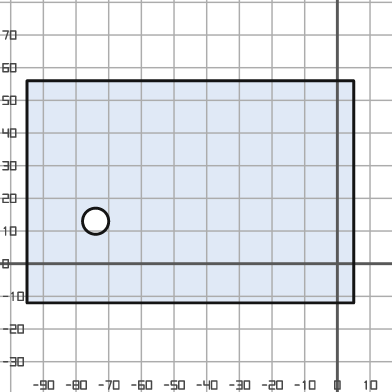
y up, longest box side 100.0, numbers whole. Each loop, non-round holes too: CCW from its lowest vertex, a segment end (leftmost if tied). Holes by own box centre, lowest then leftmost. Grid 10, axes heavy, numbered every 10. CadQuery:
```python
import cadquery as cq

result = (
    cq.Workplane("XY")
    .moveTo(-95.0, -12.0)
    .lineTo(5.0, -12.0)
    .lineTo(5.0, 56.0)
    .lineTo(-95.0, 56.0)
    .close()
    .moveTo(-74.0, 13.0)
    .circle(4.0)
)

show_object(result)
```